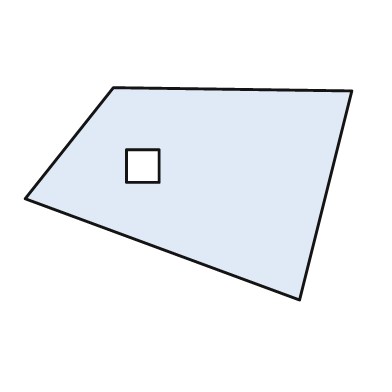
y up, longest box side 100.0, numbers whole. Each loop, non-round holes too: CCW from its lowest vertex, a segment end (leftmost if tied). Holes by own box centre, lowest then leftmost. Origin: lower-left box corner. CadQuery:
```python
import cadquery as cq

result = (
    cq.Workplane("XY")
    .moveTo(84.0, 0.0)
    .lineTo(100.0, 64.0)
    .lineTo(27.0, 65.0)
    .lineTo(0.0, 31.0)
    .close()
    .moveTo(31.0, 36.0)
    .lineTo(41.0, 36.0)
    .lineTo(41.0, 46.0)
    .lineTo(31.0, 46.0)
    .close()
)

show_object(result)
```